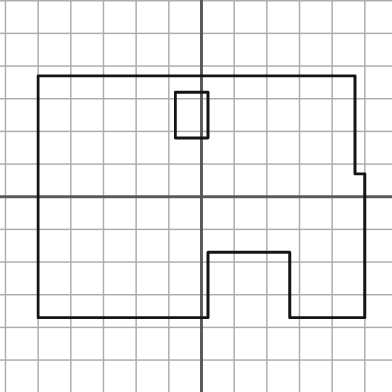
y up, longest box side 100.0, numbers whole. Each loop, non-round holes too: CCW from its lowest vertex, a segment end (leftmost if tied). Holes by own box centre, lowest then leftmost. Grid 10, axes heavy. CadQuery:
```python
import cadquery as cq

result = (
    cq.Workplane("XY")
    .moveTo(-50.0, -37.0)
    .lineTo(2.0, -37.0)
    .lineTo(2.0, -17.0)
    .lineTo(27.0, -17.0)
    .lineTo(27.0, -37.0)
    .lineTo(50.0, -37.0)
    .lineTo(50.0, 7.0)
    .lineTo(47.0, 7.0)
    .lineTo(47.0, 37.0)
    .lineTo(-50.0, 37.0)
    .close()
    .moveTo(-8.0, 18.0)
    .lineTo(2.0, 18.0)
    .lineTo(2.0, 32.0)
    .lineTo(-8.0, 32.0)
    .close()
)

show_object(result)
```